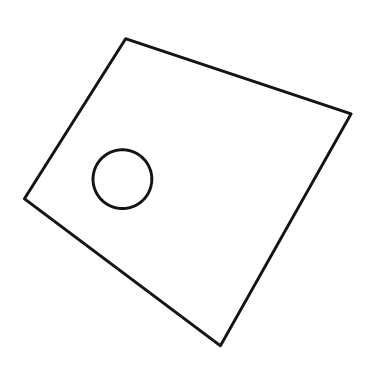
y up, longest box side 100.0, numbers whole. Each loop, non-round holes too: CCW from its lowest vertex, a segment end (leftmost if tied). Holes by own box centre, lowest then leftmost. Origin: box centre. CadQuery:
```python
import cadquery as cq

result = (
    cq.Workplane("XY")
    .moveTo(10.0, -47.0)
    .lineTo(50.0, 24.0)
    .lineTo(-19.0, 47.0)
    .lineTo(-50.0, -2.0)
    .close()
    .moveTo(-20.0, 4.0)
    .circle(9.0)
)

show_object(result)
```